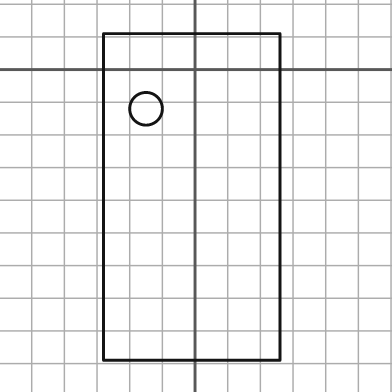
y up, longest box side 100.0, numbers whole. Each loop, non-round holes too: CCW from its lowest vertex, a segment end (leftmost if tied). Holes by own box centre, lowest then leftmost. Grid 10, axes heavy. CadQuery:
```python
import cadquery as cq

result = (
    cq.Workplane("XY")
    .moveTo(-28.0, -89.0)
    .lineTo(26.0, -89.0)
    .lineTo(26.0, 11.0)
    .lineTo(-28.0, 11.0)
    .close()
    .moveTo(-15.0, -12.0)
    .circle(5.0)
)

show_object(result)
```